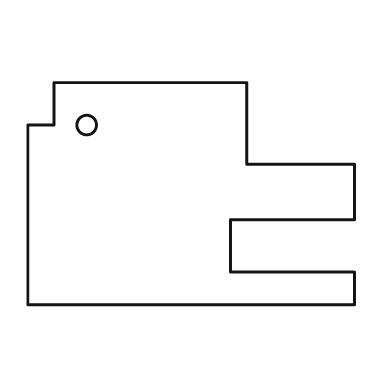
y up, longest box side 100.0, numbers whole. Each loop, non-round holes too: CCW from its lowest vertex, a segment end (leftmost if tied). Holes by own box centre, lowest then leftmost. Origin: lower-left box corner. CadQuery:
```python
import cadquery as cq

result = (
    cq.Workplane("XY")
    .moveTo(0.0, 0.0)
    .lineTo(100.0, 0.0)
    .lineTo(100.0, 10.0)
    .lineTo(62.0, 10.0)
    .lineTo(62.0, 26.0)
    .lineTo(100.0, 26.0)
    .lineTo(100.0, 43.0)
    .lineTo(67.0, 43.0)
    .lineTo(67.0, 68.0)
    .lineTo(8.0, 68.0)
    .lineTo(8.0, 55.0)
    .lineTo(0.0, 55.0)
    .close()
    .moveTo(18.0, 55.0)
    .circle(3.0)
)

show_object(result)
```